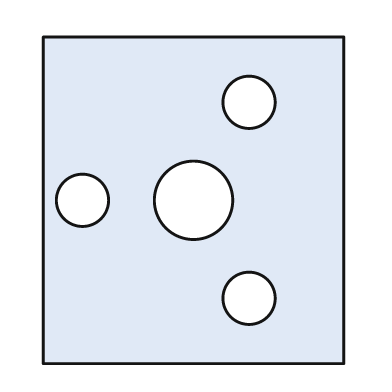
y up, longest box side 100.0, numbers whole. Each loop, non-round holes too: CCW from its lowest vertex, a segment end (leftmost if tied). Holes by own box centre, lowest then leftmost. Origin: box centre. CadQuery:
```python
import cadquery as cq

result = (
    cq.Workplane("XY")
    .moveTo(-46.0, -50.0)
    .lineTo(46.0, -50.0)
    .lineTo(46.0, 50.0)
    .lineTo(-46.0, 50.0)
    .close()
    .moveTo(17.0, -30.0)
    .circle(8.0)
    .moveTo(-34.0, 0.0)
    .circle(8.0)
    .moveTo(0.0, 0.0)
    .circle(12.0)
    .moveTo(17.0, 30.0)
    .circle(8.0)
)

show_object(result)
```